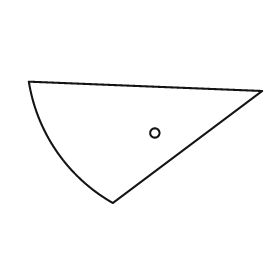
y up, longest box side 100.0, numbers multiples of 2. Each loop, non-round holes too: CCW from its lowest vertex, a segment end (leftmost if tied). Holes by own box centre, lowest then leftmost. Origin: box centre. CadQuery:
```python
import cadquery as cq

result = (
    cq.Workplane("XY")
    .moveTo(-14.0, -26.0)
    .lineTo(50.0, 22.0)
    .lineTo(-50.0, 26.0)
    .threePointArc((-38.0, -4.0), (-14.0, -26.0))
    .close()
    .moveTo(4.0, 4.0)
    .circle(2.0)
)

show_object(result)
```